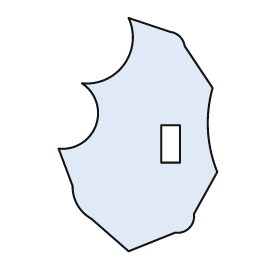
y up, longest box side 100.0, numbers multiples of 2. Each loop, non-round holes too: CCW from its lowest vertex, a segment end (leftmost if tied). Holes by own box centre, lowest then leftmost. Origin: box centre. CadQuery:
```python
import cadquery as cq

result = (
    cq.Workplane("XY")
    .moveTo(-4.0, -50.0)
    .lineTo(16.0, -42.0)
    .threePointArc((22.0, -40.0), (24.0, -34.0))
    .lineTo(34.0, -16.0)
    .threePointArc((30.0, 2.0), (32.0, 20.0))
    .lineTo(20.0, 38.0)
    .threePointArc((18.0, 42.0), (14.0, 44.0))
    .lineTo(-4.0, 50.0)
    .threePointArc((-6.0, 30.0), (-24.0, 22.0))
    .threePointArc((-18.0, 4.0), (-34.0, -6.0))
    .lineTo(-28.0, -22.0)
    .threePointArc((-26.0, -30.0), (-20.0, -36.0))
    .close()
    .moveTo(10.0, -12.0)
    .lineTo(18.0, -12.0)
    .lineTo(18.0, 4.0)
    .lineTo(10.0, 4.0)
    .close()
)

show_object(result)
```